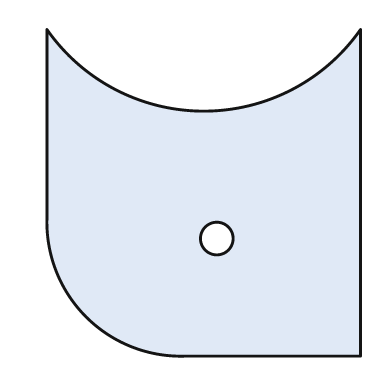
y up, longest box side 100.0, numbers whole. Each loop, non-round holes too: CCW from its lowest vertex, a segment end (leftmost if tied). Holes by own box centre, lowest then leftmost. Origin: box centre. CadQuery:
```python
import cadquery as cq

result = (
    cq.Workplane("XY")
    .moveTo(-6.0, -50.0)
    .lineTo(48.0, -50.0)
    .lineTo(48.0, 50.0)
    .threePointArc((0.0, 25.0), (-48.0, 50.0))
    .lineTo(-48.0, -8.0)
    .threePointArc((-36.0, -38.0), (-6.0, -50.0))
    .close()
    .moveTo(4.0, -14.0)
    .circle(5.0)
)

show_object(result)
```